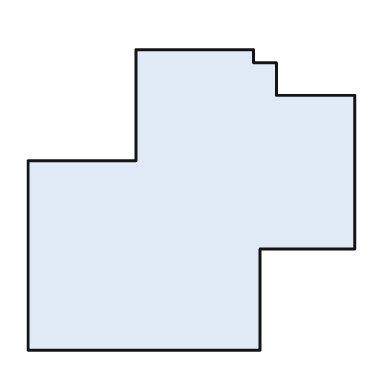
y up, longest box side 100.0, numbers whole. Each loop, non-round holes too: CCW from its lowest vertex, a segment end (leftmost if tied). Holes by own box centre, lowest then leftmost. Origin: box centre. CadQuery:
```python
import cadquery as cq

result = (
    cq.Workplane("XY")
    .moveTo(-50.0, -46.0)
    .lineTo(21.0, -46.0)
    .lineTo(21.0, -15.0)
    .lineTo(50.0, -15.0)
    .lineTo(50.0, 32.0)
    .lineTo(26.0, 32.0)
    .lineTo(26.0, 42.0)
    .lineTo(19.0, 42.0)
    .lineTo(19.0, 46.0)
    .lineTo(-17.0, 46.0)
    .lineTo(-17.0, 12.0)
    .lineTo(-50.0, 12.0)
    .close()
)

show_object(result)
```